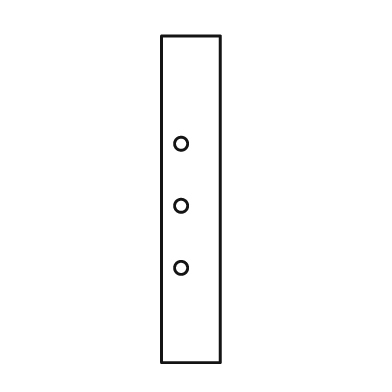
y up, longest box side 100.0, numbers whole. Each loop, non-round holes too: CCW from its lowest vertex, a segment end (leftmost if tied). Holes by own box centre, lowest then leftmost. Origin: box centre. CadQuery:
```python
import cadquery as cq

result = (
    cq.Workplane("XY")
    .moveTo(-9.0, -50.0)
    .lineTo(9.0, -50.0)
    .lineTo(9.0, 50.0)
    .lineTo(-9.0, 50.0)
    .close()
    .moveTo(-3.0, -21.0)
    .circle(2.0)
    .moveTo(-3.0, -2.0)
    .circle(2.0)
    .moveTo(-3.0, 17.0)
    .circle(2.0)
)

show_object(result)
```